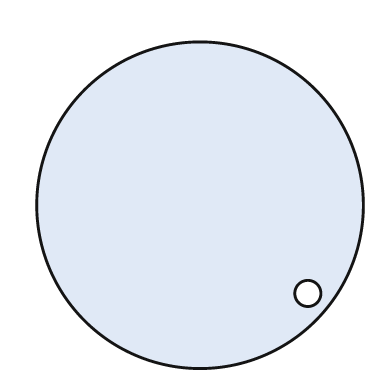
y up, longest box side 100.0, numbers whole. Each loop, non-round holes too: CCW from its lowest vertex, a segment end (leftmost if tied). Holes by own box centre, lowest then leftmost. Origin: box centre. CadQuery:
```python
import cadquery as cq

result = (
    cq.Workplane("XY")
    .moveTo(0.0, 0.0)
    .circle(50.0)
    .moveTo(33.0, -27.0)
    .circle(4.0)
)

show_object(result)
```